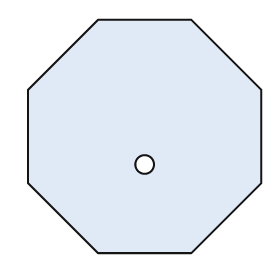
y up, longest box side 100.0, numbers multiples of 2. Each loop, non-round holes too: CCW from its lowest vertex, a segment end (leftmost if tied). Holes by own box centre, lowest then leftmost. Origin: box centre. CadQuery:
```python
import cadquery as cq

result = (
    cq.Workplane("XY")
    .moveTo(-20.0, -50.0)
    .lineTo(20.0, -50.0)
    .lineTo(50.0, -20.0)
    .lineTo(50.0, 20.0)
    .lineTo(20.0, 50.0)
    .lineTo(-20.0, 50.0)
    .lineTo(-50.0, 20.0)
    .lineTo(-50.0, -20.0)
    .close()
    .moveTo(0.0, -12.0)
    .circle(4.0)
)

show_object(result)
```